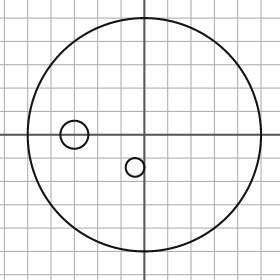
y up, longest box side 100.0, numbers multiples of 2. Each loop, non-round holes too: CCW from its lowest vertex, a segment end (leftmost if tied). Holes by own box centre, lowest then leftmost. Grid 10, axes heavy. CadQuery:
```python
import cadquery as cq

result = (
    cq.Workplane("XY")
    .moveTo(0.0, 0.0)
    .circle(50.0)
    .moveTo(-4.0, -14.0)
    .circle(4.0)
    .moveTo(-30.0, 0.0)
    .circle(6.0)
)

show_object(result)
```